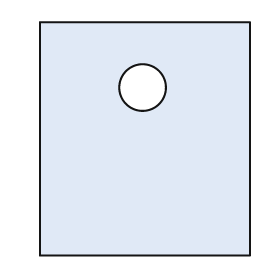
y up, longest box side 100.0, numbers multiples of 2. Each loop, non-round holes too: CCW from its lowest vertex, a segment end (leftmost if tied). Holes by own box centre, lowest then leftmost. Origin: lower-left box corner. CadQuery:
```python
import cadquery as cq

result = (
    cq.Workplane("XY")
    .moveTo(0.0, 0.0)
    .lineTo(90.0, 0.0)
    .lineTo(90.0, 100.0)
    .lineTo(0.0, 100.0)
    .close()
    .moveTo(44.0, 72.0)
    .circle(10.0)
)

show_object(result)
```